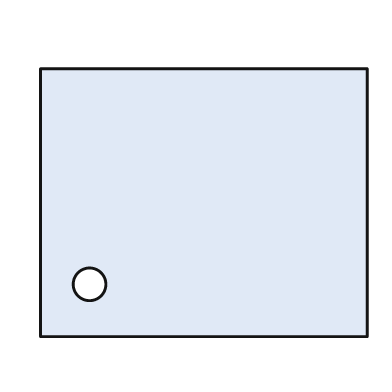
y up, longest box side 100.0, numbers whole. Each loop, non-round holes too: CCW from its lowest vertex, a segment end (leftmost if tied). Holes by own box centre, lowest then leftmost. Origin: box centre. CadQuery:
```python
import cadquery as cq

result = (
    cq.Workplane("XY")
    .moveTo(-50.0, -41.0)
    .lineTo(50.0, -41.0)
    .lineTo(50.0, 41.0)
    .lineTo(-50.0, 41.0)
    .close()
    .moveTo(-35.0, -25.0)
    .circle(5.0)
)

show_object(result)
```